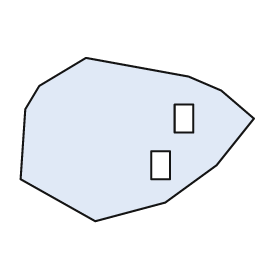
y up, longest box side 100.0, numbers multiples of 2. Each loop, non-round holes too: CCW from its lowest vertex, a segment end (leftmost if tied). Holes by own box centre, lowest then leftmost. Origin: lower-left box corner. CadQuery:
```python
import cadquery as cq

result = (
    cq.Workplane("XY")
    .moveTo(32.0, 0.0)
    .lineTo(62.0, 8.0)
    .lineTo(84.0, 24.0)
    .lineTo(100.0, 44.0)
    .lineTo(86.0, 56.0)
    .lineTo(72.0, 62.0)
    .lineTo(28.0, 70.0)
    .lineTo(8.0, 58.0)
    .lineTo(2.0, 48.0)
    .lineTo(0.0, 18.0)
    .close()
    .moveTo(56.0, 18.0)
    .lineTo(64.0, 18.0)
    .lineTo(64.0, 30.0)
    .lineTo(56.0, 30.0)
    .close()
    .moveTo(66.0, 38.0)
    .lineTo(74.0, 38.0)
    .lineTo(74.0, 50.0)
    .lineTo(66.0, 50.0)
    .close()
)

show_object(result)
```